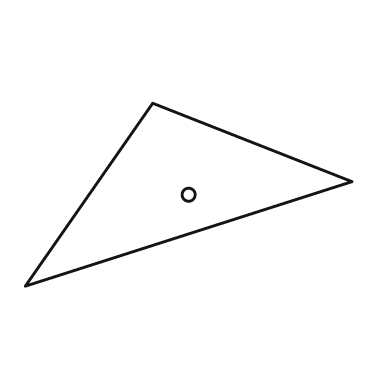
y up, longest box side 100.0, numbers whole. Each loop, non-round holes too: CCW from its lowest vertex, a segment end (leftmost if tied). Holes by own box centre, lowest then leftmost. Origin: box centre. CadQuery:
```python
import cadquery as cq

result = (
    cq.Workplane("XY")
    .moveTo(-50.0, -28.0)
    .lineTo(50.0, 4.0)
    .lineTo(-11.0, 28.0)
    .close()
    .moveTo(0.0, 0.0)
    .circle(2.0)
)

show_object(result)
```